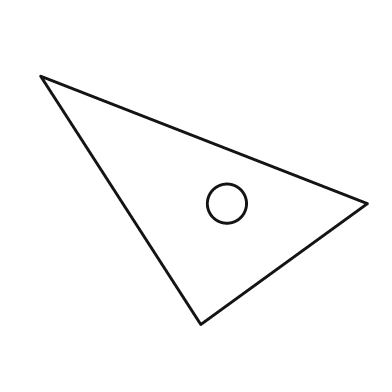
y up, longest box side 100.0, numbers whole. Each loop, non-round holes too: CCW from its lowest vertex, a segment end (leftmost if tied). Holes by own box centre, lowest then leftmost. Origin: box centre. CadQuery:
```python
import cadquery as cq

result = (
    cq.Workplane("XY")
    .moveTo(-1.0, -38.0)
    .lineTo(50.0, -1.0)
    .lineTo(-50.0, 38.0)
    .close()
    .moveTo(7.0, -1.0)
    .circle(6.0)
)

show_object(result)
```